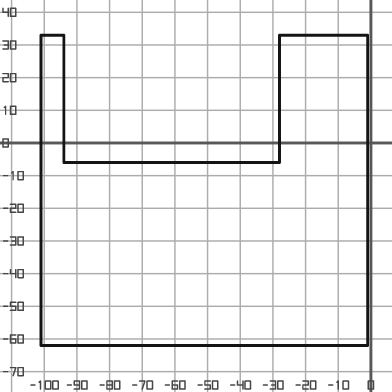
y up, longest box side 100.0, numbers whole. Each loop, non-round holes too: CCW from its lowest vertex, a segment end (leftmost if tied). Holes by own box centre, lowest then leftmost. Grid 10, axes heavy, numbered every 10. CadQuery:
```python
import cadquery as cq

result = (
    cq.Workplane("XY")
    .moveTo(-101.0, -62.0)
    .lineTo(-1.0, -62.0)
    .lineTo(-1.0, 33.0)
    .lineTo(-28.0, 33.0)
    .lineTo(-28.0, -6.0)
    .lineTo(-94.0, -6.0)
    .lineTo(-94.0, 33.0)
    .lineTo(-101.0, 33.0)
    .close()
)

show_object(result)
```